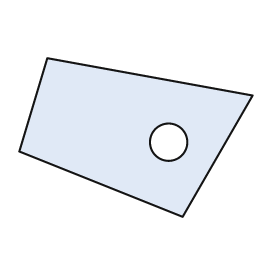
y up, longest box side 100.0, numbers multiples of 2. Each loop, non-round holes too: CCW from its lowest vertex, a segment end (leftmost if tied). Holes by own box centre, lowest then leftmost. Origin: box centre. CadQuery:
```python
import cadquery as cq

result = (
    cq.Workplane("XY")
    .moveTo(20.0, -34.0)
    .lineTo(50.0, 18.0)
    .lineTo(-38.0, 34.0)
    .lineTo(-50.0, -6.0)
    .close()
    .moveTo(14.0, -2.0)
    .circle(8.0)
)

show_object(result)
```